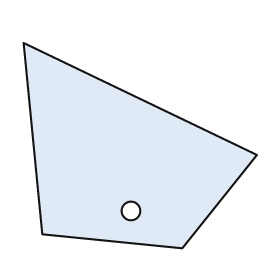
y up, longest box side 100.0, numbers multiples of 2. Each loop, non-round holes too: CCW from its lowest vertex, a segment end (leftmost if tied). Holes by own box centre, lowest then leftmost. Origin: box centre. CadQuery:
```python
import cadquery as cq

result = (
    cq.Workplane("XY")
    .moveTo(18.0, -44.0)
    .lineTo(50.0, -4.0)
    .lineTo(-50.0, 44.0)
    .lineTo(-42.0, -38.0)
    .close()
    .moveTo(-4.0, -28.0)
    .circle(4.0)
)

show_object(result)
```